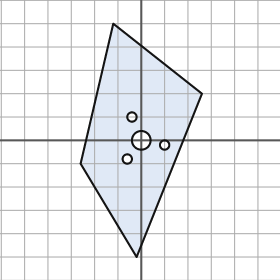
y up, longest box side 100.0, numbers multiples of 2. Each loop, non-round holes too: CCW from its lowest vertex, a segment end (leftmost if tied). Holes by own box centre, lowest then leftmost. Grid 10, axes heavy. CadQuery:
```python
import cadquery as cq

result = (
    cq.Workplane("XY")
    .moveTo(-2.0, -50.0)
    .lineTo(26.0, 20.0)
    .lineTo(-12.0, 50.0)
    .lineTo(-26.0, -10.0)
    .close()
    .moveTo(-6.0, -8.0)
    .circle(2.0)
    .moveTo(10.0, -2.0)
    .circle(2.0)
    .moveTo(0.0, 0.0)
    .circle(4.0)
    .moveTo(-4.0, 10.0)
    .circle(2.0)
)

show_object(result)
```